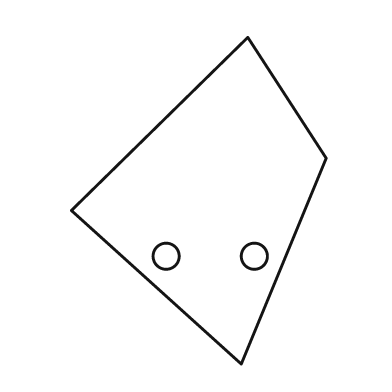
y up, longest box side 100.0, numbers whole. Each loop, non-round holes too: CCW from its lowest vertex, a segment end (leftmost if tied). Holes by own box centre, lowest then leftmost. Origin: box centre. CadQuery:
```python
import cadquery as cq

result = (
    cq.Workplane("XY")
    .moveTo(13.0, -50.0)
    .lineTo(39.0, 13.0)
    .lineTo(15.0, 50.0)
    .lineTo(-39.0, -3.0)
    .close()
    .moveTo(-10.0, -17.0)
    .circle(4.0)
    .moveTo(17.0, -17.0)
    .circle(4.0)
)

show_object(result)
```